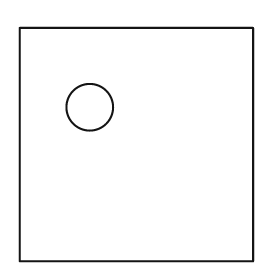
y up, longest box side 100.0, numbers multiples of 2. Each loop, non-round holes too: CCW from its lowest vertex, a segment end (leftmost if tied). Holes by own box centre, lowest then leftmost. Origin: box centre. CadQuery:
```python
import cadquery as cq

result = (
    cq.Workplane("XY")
    .moveTo(-50.0, -50.0)
    .lineTo(50.0, -50.0)
    .lineTo(50.0, 50.0)
    .lineTo(-50.0, 50.0)
    .close()
    .moveTo(-20.0, 16.0)
    .circle(10.0)
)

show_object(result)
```